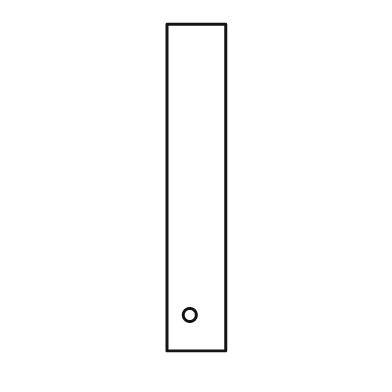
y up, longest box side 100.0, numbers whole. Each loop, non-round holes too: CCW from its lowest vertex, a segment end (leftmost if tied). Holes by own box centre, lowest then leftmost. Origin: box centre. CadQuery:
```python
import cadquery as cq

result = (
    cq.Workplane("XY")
    .moveTo(-9.0, -50.0)
    .lineTo(9.0, -50.0)
    .lineTo(9.0, 50.0)
    .lineTo(-9.0, 50.0)
    .close()
    .moveTo(-2.0, -39.0)
    .circle(2.0)
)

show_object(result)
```